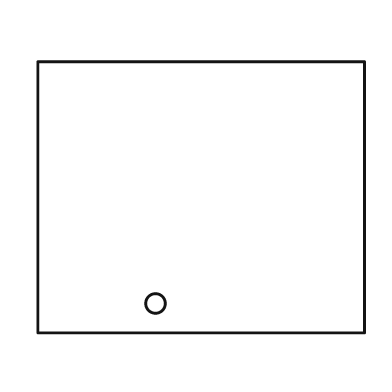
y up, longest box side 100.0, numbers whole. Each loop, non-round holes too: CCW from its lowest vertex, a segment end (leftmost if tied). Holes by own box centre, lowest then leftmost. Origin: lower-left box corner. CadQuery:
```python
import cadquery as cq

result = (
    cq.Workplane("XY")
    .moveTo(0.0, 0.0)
    .lineTo(100.0, 0.0)
    .lineTo(100.0, 83.0)
    .lineTo(0.0, 83.0)
    .close()
    .moveTo(36.0, 9.0)
    .circle(3.0)
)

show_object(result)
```